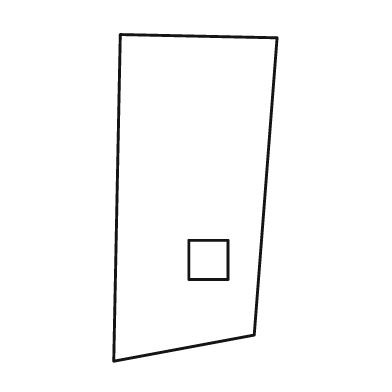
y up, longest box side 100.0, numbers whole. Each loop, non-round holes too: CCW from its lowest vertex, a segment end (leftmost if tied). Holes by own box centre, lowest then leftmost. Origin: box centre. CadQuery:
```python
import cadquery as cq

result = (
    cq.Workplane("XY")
    .moveTo(-25.0, -50.0)
    .lineTo(18.0, -42.0)
    .lineTo(25.0, 49.0)
    .lineTo(-23.0, 50.0)
    .close()
    .moveTo(-2.0, -25.0)
    .lineTo(10.0, -25.0)
    .lineTo(10.0, -13.0)
    .lineTo(-2.0, -13.0)
    .close()
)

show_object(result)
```